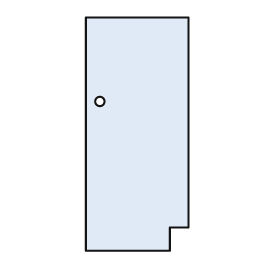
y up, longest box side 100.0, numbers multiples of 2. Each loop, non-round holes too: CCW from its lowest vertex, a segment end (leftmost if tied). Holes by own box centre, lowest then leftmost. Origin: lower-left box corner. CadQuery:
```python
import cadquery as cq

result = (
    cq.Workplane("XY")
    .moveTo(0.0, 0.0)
    .lineTo(36.0, 0.0)
    .lineTo(36.0, 10.0)
    .lineTo(44.0, 10.0)
    .lineTo(44.0, 100.0)
    .lineTo(0.0, 100.0)
    .close()
    .moveTo(6.0, 64.0)
    .circle(2.0)
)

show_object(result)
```